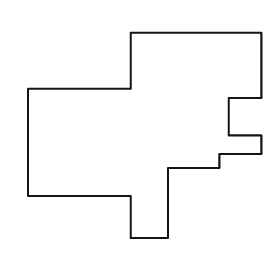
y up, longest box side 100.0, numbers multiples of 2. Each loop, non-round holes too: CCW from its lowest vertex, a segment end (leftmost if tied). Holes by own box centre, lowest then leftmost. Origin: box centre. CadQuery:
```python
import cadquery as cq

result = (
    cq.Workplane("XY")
    .moveTo(-6.0, -44.0)
    .lineTo(10.0, -44.0)
    .lineTo(10.0, -14.0)
    .lineTo(32.0, -14.0)
    .lineTo(32.0, -8.0)
    .lineTo(50.0, -8.0)
    .lineTo(50.0, 0.0)
    .lineTo(36.0, 0.0)
    .lineTo(36.0, 16.0)
    .lineTo(50.0, 16.0)
    .lineTo(50.0, 44.0)
    .lineTo(-6.0, 44.0)
    .lineTo(-6.0, 20.0)
    .lineTo(-50.0, 20.0)
    .lineTo(-50.0, -26.0)
    .lineTo(-6.0, -26.0)
    .close()
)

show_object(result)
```